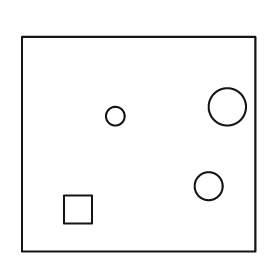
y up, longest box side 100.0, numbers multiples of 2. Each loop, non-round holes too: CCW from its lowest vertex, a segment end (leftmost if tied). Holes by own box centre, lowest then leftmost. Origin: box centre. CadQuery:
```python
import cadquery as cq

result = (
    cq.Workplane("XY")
    .moveTo(-50.0, -46.0)
    .lineTo(50.0, -46.0)
    .lineTo(50.0, 46.0)
    .lineTo(-50.0, 46.0)
    .close()
    .moveTo(-32.0, -34.0)
    .lineTo(-20.0, -34.0)
    .lineTo(-20.0, -22.0)
    .lineTo(-32.0, -22.0)
    .close()
    .moveTo(30.0, -18.0)
    .circle(6.0)
    .moveTo(-10.0, 12.0)
    .circle(4.0)
    .moveTo(38.0, 16.0)
    .circle(8.0)
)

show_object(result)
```